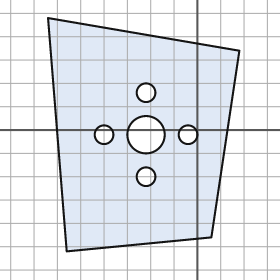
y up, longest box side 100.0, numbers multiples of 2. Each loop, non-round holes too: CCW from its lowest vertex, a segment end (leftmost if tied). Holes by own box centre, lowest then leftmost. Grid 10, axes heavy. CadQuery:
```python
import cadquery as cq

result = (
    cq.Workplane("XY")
    .moveTo(-56.0, -52.0)
    .lineTo(6.0, -46.0)
    .lineTo(18.0, 34.0)
    .lineTo(-64.0, 48.0)
    .close()
    .moveTo(-22.0, -20.0)
    .circle(4.0)
    .moveTo(-40.0, -2.0)
    .circle(4.0)
    .moveTo(-22.0, -2.0)
    .circle(8.0)
    .moveTo(-4.0, -2.0)
    .circle(4.0)
    .moveTo(-22.0, 16.0)
    .circle(4.0)
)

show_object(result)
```